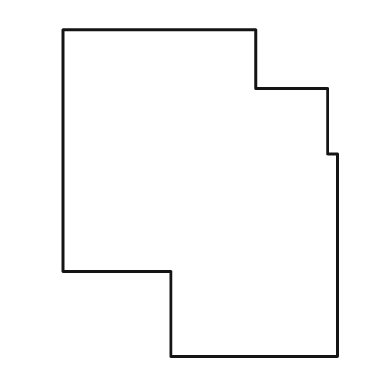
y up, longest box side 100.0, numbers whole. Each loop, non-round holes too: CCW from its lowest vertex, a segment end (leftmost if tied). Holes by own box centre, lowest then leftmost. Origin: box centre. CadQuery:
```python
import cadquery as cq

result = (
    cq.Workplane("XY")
    .moveTo(-9.0, -50.0)
    .lineTo(42.0, -50.0)
    .lineTo(42.0, 12.0)
    .lineTo(39.0, 12.0)
    .lineTo(39.0, 32.0)
    .lineTo(17.0, 32.0)
    .lineTo(17.0, 50.0)
    .lineTo(-42.0, 50.0)
    .lineTo(-42.0, -24.0)
    .lineTo(-9.0, -24.0)
    .close()
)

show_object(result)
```